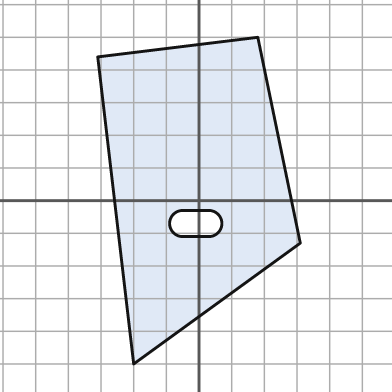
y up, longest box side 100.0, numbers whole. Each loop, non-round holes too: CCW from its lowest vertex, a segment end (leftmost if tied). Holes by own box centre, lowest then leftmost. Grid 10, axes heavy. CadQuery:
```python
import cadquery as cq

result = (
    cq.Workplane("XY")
    .moveTo(-20.0, -50.0)
    .lineTo(31.0, -13.0)
    .lineTo(18.0, 50.0)
    .lineTo(-31.0, 44.0)
    .close()
    .moveTo(-5.0, -11.0)
    .lineTo(3.0, -11.0)
    .threePointArc((7.0, -7.0), (3.0, -3.0))
    .lineTo(-5.0, -3.0)
    .threePointArc((-9.0, -7.0), (-5.0, -11.0))
    .close()
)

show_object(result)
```